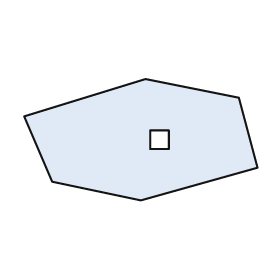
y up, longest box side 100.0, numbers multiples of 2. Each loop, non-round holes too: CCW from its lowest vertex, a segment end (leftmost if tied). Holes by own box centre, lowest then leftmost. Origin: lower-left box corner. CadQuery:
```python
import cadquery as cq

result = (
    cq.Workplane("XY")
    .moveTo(50.0, 0.0)
    .lineTo(100.0, 14.0)
    .lineTo(92.0, 44.0)
    .lineTo(52.0, 52.0)
    .lineTo(0.0, 36.0)
    .lineTo(12.0, 8.0)
    .close()
    .moveTo(54.0, 22.0)
    .lineTo(62.0, 22.0)
    .lineTo(62.0, 30.0)
    .lineTo(54.0, 30.0)
    .close()
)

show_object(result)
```